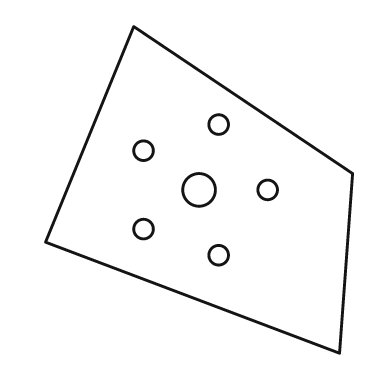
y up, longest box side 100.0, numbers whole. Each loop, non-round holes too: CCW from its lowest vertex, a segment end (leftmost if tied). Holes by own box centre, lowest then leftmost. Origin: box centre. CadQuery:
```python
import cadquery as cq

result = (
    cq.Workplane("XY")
    .moveTo(43.0, -50.0)
    .lineTo(47.0, 5.0)
    .lineTo(-20.0, 50.0)
    .lineTo(-47.0, -16.0)
    .close()
    .moveTo(6.0, -20.0)
    .circle(3.0)
    .moveTo(-17.0, -12.0)
    .circle(3.0)
    .moveTo(0.0, 0.0)
    .circle(5.0)
    .moveTo(21.0, 0.0)
    .circle(3.0)
    .moveTo(-17.0, 12.0)
    .circle(3.0)
    .moveTo(6.0, 20.0)
    .circle(3.0)
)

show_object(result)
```